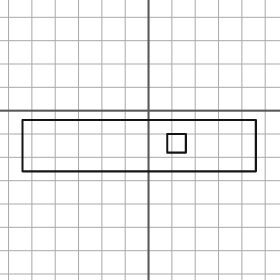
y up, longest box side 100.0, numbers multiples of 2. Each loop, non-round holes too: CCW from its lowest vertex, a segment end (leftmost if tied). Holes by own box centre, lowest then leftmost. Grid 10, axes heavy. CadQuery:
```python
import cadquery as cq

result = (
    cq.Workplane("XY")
    .moveTo(-54.0, -26.0)
    .lineTo(46.0, -26.0)
    .lineTo(46.0, -4.0)
    .lineTo(-54.0, -4.0)
    .close()
    .moveTo(8.0, -18.0)
    .lineTo(16.0, -18.0)
    .lineTo(16.0, -10.0)
    .lineTo(8.0, -10.0)
    .close()
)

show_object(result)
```